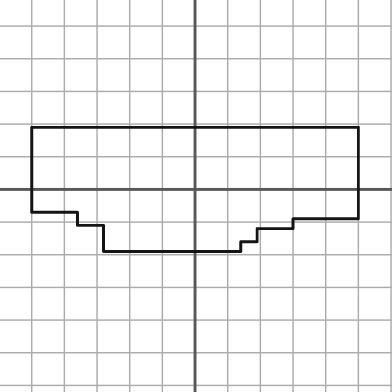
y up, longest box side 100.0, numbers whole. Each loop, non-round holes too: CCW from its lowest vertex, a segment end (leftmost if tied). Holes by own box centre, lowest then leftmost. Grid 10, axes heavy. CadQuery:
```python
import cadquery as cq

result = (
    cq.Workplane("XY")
    .moveTo(-28.0, -19.0)
    .lineTo(14.0, -19.0)
    .lineTo(14.0, -16.0)
    .lineTo(19.0, -16.0)
    .lineTo(19.0, -12.0)
    .lineTo(30.0, -12.0)
    .lineTo(30.0, -9.0)
    .lineTo(50.0, -9.0)
    .lineTo(50.0, 19.0)
    .lineTo(-50.0, 19.0)
    .lineTo(-50.0, -7.0)
    .lineTo(-36.0, -7.0)
    .lineTo(-36.0, -11.0)
    .lineTo(-28.0, -11.0)
    .close()
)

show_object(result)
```